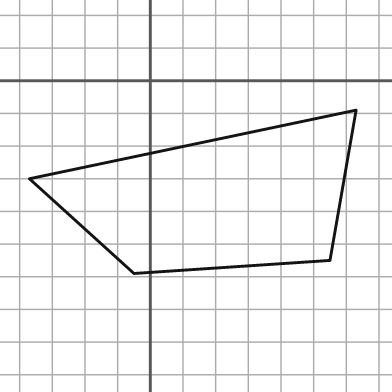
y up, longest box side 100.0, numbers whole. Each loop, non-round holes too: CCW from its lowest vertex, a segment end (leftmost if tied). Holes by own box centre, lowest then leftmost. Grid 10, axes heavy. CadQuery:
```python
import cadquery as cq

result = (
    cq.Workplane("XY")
    .moveTo(-5.0, -59.0)
    .lineTo(55.0, -55.0)
    .lineTo(63.0, -9.0)
    .lineTo(-37.0, -30.0)
    .close()
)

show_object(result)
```